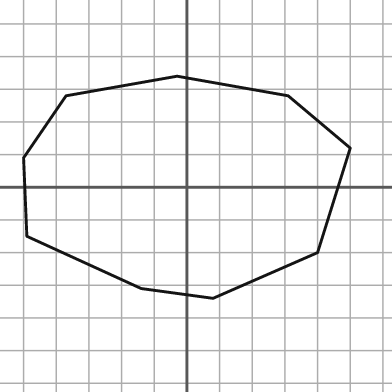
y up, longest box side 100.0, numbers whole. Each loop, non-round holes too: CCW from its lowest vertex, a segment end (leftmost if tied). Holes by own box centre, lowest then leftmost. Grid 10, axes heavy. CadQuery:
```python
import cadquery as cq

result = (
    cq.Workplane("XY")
    .moveTo(8.0, -34.0)
    .lineTo(40.0, -20.0)
    .lineTo(50.0, 12.0)
    .lineTo(31.0, 28.0)
    .lineTo(-3.0, 34.0)
    .lineTo(-37.0, 28.0)
    .lineTo(-50.0, 9.0)
    .lineTo(-49.0, -15.0)
    .lineTo(-14.0, -31.0)
    .close()
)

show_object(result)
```